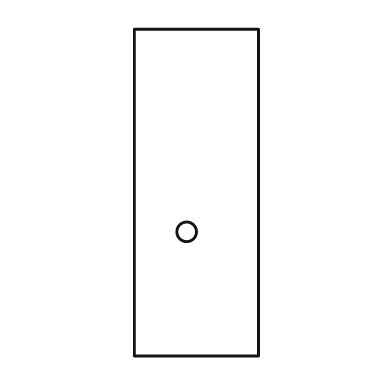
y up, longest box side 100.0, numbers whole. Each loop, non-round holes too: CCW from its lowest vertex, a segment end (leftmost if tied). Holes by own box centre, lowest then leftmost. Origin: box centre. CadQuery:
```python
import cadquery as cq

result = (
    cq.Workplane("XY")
    .moveTo(-19.0, -50.0)
    .lineTo(19.0, -50.0)
    .lineTo(19.0, 50.0)
    .lineTo(-19.0, 50.0)
    .close()
    .moveTo(-3.0, -12.0)
    .circle(3.0)
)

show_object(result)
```